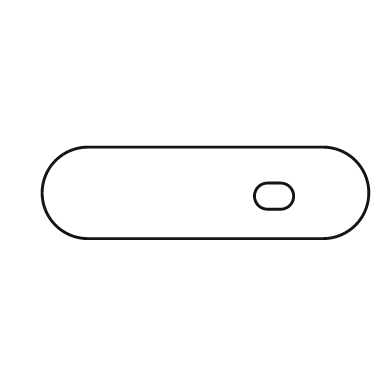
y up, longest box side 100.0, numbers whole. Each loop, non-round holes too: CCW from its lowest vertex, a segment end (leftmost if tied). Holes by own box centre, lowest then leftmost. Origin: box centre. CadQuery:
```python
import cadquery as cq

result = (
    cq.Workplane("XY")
    .moveTo(-36.0, -14.0)
    .lineTo(36.0, -14.0)
    .threePointArc((50.0, 0.0), (36.0, 14.0))
    .lineTo(-36.0, 14.0)
    .threePointArc((-50.0, 0.0), (-36.0, -14.0))
    .close()
    .moveTo(19.0, -5.0)
    .lineTo(23.0, -5.0)
    .threePointArc((27.0, -1.0), (23.0, 3.0))
    .lineTo(19.0, 3.0)
    .threePointArc((15.0, -1.0), (19.0, -5.0))
    .close()
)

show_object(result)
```